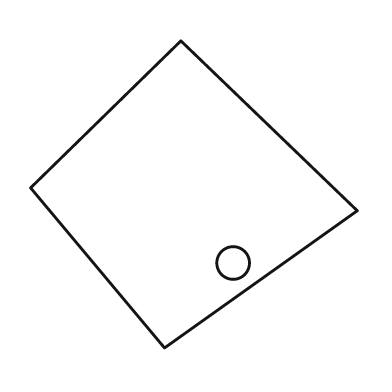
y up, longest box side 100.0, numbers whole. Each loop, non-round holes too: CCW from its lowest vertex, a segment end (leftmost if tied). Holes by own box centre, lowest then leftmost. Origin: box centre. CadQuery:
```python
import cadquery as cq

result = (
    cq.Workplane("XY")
    .moveTo(-9.0, -47.0)
    .lineTo(50.0, -5.0)
    .lineTo(-4.0, 47.0)
    .lineTo(-50.0, 2.0)
    .close()
    .moveTo(12.0, -21.0)
    .circle(5.0)
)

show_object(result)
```